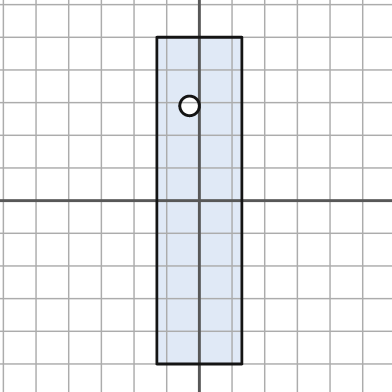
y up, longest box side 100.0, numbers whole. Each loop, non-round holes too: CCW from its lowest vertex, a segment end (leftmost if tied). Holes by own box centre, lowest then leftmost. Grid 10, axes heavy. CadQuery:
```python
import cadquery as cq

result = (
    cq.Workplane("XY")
    .moveTo(-13.0, -50.0)
    .lineTo(13.0, -50.0)
    .lineTo(13.0, 50.0)
    .lineTo(-13.0, 50.0)
    .close()
    .moveTo(-3.0, 29.0)
    .circle(3.0)
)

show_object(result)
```